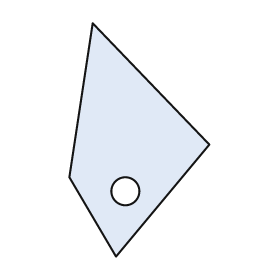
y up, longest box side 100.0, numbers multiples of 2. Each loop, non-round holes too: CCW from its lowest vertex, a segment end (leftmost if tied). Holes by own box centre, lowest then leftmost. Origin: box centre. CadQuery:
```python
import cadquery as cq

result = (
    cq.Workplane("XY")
    .moveTo(-10.0, -50.0)
    .lineTo(30.0, -2.0)
    .lineTo(-20.0, 50.0)
    .lineTo(-30.0, -16.0)
    .close()
    .moveTo(-6.0, -22.0)
    .circle(6.0)
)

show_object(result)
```